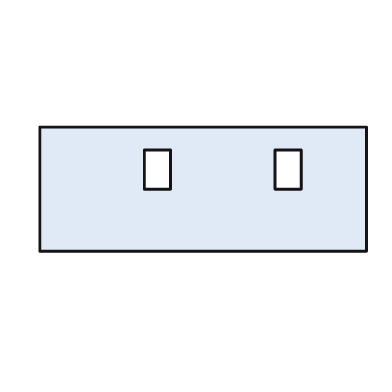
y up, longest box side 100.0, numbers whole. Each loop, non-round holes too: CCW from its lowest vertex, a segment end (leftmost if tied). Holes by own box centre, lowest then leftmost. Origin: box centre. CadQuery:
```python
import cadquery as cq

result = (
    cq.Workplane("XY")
    .moveTo(-50.0, -19.0)
    .lineTo(50.0, -19.0)
    .lineTo(50.0, 19.0)
    .lineTo(-50.0, 19.0)
    .close()
    .moveTo(-18.0, 0.0)
    .lineTo(-10.0, 0.0)
    .lineTo(-10.0, 12.0)
    .lineTo(-18.0, 12.0)
    .close()
    .moveTo(22.0, 0.0)
    .lineTo(30.0, 0.0)
    .lineTo(30.0, 12.0)
    .lineTo(22.0, 12.0)
    .close()
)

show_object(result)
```